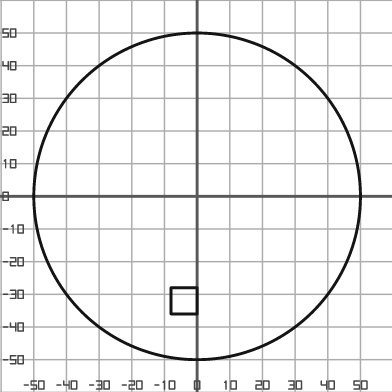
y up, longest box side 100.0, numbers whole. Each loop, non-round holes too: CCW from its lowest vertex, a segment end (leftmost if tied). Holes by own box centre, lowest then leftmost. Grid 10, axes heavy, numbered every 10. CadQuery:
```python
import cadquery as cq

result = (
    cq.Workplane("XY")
    .moveTo(0.0, 0.0)
    .circle(50.0)
    .moveTo(-8.0, -36.0)
    .lineTo(0.0, -36.0)
    .lineTo(0.0, -28.0)
    .lineTo(-8.0, -28.0)
    .close()
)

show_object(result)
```